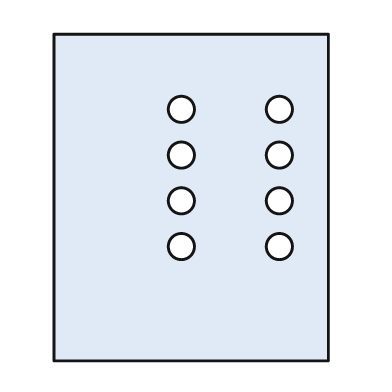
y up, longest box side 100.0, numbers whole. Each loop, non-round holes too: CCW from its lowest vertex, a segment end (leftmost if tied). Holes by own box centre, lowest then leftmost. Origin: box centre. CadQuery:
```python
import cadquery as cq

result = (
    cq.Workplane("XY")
    .moveTo(-42.0, -50.0)
    .lineTo(42.0, -50.0)
    .lineTo(42.0, 50.0)
    .lineTo(-42.0, 50.0)
    .close()
    .moveTo(-3.0, -15.0)
    .circle(4.0)
    .moveTo(27.0, -15.0)
    .circle(4.0)
    .moveTo(-3.0, -1.0)
    .circle(4.0)
    .moveTo(27.0, -1.0)
    .circle(4.0)
    .moveTo(-3.0, 13.0)
    .circle(4.0)
    .moveTo(27.0, 13.0)
    .circle(4.0)
    .moveTo(-3.0, 27.0)
    .circle(4.0)
    .moveTo(27.0, 27.0)
    .circle(4.0)
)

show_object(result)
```